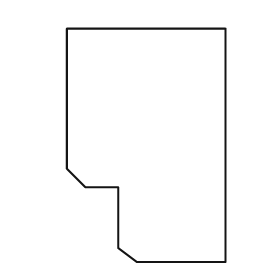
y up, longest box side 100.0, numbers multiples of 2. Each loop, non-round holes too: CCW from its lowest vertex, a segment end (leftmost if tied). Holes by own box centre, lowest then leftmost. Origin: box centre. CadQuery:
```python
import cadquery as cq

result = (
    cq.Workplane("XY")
    .moveTo(-4.0, -50.0)
    .lineTo(34.0, -50.0)
    .lineTo(34.0, 50.0)
    .lineTo(-34.0, 50.0)
    .lineTo(-34.0, -10.0)
    .lineTo(-26.0, -18.0)
    .lineTo(-12.0, -18.0)
    .lineTo(-12.0, -44.0)
    .close()
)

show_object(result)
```